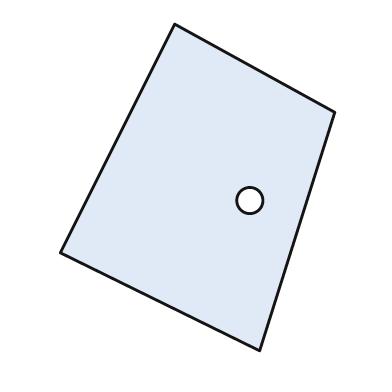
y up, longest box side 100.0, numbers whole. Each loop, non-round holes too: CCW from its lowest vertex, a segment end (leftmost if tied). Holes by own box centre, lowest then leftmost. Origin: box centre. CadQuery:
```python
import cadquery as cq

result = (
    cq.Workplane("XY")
    .moveTo(19.0, -50.0)
    .lineTo(42.0, 23.0)
    .lineTo(-7.0, 50.0)
    .lineTo(-42.0, -20.0)
    .close()
    .moveTo(16.0, -4.0)
    .circle(4.0)
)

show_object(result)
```